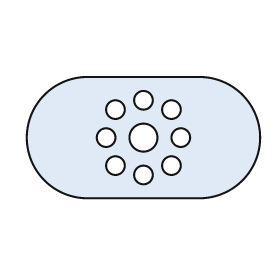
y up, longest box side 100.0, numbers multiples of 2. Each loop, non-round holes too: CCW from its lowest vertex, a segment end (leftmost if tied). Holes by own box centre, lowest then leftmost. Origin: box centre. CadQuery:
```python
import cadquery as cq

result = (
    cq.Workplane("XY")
    .moveTo(-24.0, -26.0)
    .lineTo(24.0, -26.0)
    .threePointArc((50.0, 0.0), (24.0, 26.0))
    .lineTo(-24.0, 26.0)
    .threePointArc((-50.0, 0.0), (-24.0, -26.0))
    .close()
    .moveTo(0.0, -16.0)
    .circle(4.0)
    .moveTo(-12.0, -12.0)
    .circle(4.0)
    .moveTo(12.0, -12.0)
    .circle(4.0)
    .moveTo(-16.0, 0.0)
    .circle(4.0)
    .moveTo(0.0, 0.0)
    .circle(6.0)
    .moveTo(16.0, 0.0)
    .circle(4.0)
    .moveTo(-12.0, 12.0)
    .circle(4.0)
    .moveTo(12.0, 12.0)
    .circle(4.0)
    .moveTo(0.0, 16.0)
    .circle(4.0)
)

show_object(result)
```